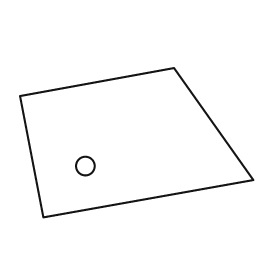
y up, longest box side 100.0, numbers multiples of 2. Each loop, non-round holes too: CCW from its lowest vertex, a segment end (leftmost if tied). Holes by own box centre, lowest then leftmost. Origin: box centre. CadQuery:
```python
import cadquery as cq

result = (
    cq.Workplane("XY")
    .moveTo(-40.0, -32.0)
    .lineTo(50.0, -16.0)
    .lineTo(16.0, 32.0)
    .lineTo(-50.0, 20.0)
    .close()
    .moveTo(-22.0, -10.0)
    .circle(4.0)
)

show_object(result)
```